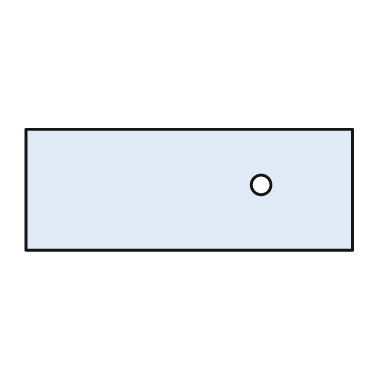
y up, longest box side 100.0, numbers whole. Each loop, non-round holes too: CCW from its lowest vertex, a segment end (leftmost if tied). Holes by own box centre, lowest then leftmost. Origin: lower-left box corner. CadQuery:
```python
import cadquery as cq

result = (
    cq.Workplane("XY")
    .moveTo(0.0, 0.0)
    .lineTo(100.0, 0.0)
    .lineTo(100.0, 37.0)
    .lineTo(0.0, 37.0)
    .close()
    .moveTo(72.0, 20.0)
    .circle(3.0)
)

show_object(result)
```